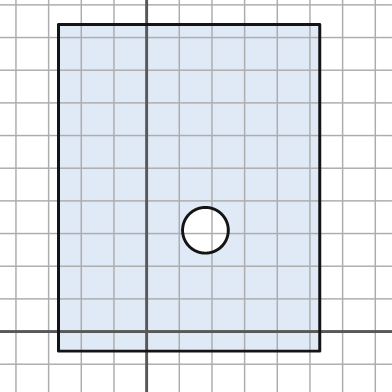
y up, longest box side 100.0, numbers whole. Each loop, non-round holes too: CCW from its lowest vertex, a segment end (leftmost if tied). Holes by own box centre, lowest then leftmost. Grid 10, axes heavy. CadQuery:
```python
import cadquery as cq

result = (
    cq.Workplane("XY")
    .moveTo(-27.0, -6.0)
    .lineTo(53.0, -6.0)
    .lineTo(53.0, 94.0)
    .lineTo(-27.0, 94.0)
    .close()
    .moveTo(18.0, 31.0)
    .circle(7.0)
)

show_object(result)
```